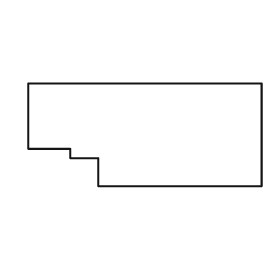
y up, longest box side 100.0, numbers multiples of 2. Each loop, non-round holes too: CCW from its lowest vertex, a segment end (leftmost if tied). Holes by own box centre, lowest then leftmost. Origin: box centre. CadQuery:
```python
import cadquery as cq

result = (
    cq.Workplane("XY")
    .moveTo(-20.0, -22.0)
    .lineTo(50.0, -22.0)
    .lineTo(50.0, 22.0)
    .lineTo(-50.0, 22.0)
    .lineTo(-50.0, -6.0)
    .lineTo(-32.0, -6.0)
    .lineTo(-32.0, -10.0)
    .lineTo(-20.0, -10.0)
    .close()
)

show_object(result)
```